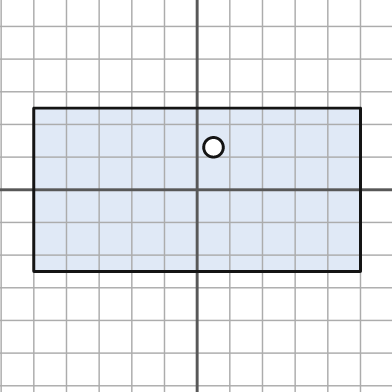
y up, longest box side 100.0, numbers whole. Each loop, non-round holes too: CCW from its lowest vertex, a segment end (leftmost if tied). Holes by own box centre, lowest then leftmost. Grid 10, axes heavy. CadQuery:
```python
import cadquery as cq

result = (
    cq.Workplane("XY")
    .moveTo(-50.0, -25.0)
    .lineTo(50.0, -25.0)
    .lineTo(50.0, 25.0)
    .lineTo(-50.0, 25.0)
    .close()
    .moveTo(5.0, 13.0)
    .circle(3.0)
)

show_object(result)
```